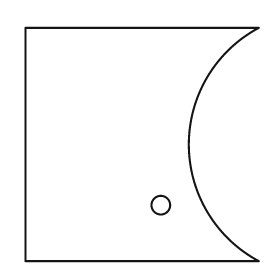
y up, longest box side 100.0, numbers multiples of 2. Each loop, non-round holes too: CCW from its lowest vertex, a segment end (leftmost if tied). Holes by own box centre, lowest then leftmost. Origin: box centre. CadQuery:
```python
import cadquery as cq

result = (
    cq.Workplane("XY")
    .moveTo(-50.0, -50.0)
    .lineTo(50.0, -50.0)
    .threePointArc((20.0, 0.0), (50.0, 50.0))
    .lineTo(-50.0, 50.0)
    .close()
    .moveTo(8.0, -26.0)
    .circle(4.0)
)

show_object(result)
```